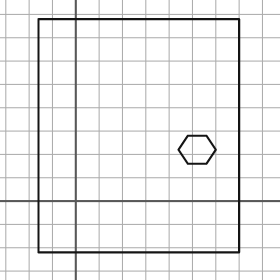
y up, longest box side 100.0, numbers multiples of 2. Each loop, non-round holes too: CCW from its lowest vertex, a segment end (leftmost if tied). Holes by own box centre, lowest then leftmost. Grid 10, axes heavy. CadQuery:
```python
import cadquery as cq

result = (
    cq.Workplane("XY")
    .moveTo(-16.0, -22.0)
    .lineTo(70.0, -22.0)
    .lineTo(70.0, 78.0)
    .lineTo(-16.0, 78.0)
    .close()
    .moveTo(48.0, 16.0)
    .lineTo(56.0, 16.0)
    .lineTo(60.0, 22.0)
    .lineTo(56.0, 28.0)
    .lineTo(48.0, 28.0)
    .lineTo(44.0, 22.0)
    .close()
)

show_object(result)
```